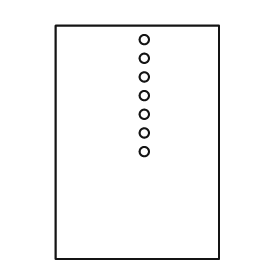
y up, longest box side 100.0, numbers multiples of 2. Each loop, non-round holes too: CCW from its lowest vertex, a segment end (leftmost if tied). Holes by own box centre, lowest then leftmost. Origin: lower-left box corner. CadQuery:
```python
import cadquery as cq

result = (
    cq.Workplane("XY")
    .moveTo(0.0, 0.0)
    .lineTo(70.0, 0.0)
    .lineTo(70.0, 100.0)
    .lineTo(0.0, 100.0)
    .close()
    .moveTo(38.0, 46.0)
    .circle(2.0)
    .moveTo(38.0, 54.0)
    .circle(2.0)
    .moveTo(38.0, 62.0)
    .circle(2.0)
    .moveTo(38.0, 70.0)
    .circle(2.0)
    .moveTo(38.0, 78.0)
    .circle(2.0)
    .moveTo(38.0, 86.0)
    .circle(2.0)
    .moveTo(38.0, 94.0)
    .circle(2.0)
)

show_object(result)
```